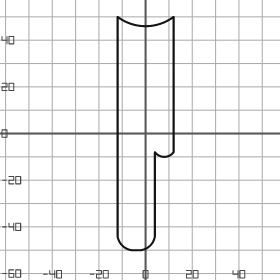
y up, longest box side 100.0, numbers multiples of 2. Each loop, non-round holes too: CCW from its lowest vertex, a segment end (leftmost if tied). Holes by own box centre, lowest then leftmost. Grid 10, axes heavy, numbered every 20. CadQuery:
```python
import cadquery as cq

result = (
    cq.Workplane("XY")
    .moveTo(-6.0, -50.0)
    .lineTo(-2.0, -50.0)
    .threePointArc((2.0, -48.0), (4.0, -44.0))
    .lineTo(4.0, -8.0)
    .threePointArc((8.0, -10.0), (12.0, -8.0))
    .lineTo(12.0, 50.0)
    .threePointArc((0.0, 46.0), (-12.0, 50.0))
    .lineTo(-12.0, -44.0)
    .threePointArc((-10.0, -48.0), (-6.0, -50.0))
    .close()
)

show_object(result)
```